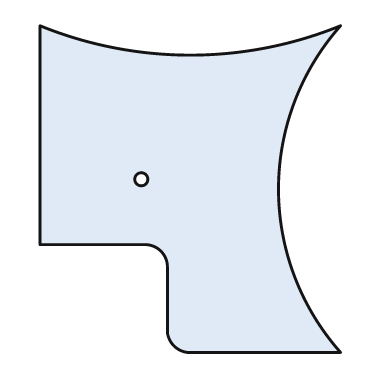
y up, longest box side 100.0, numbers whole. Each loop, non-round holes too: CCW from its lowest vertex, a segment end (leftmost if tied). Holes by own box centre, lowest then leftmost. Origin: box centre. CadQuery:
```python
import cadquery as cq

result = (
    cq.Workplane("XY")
    .moveTo(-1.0, -50.0)
    .lineTo(46.0, -50.0)
    .threePointArc((27.0, 0.0), (46.0, 50.0))
    .threePointArc((0.0, 41.0), (-46.0, 50.0))
    .lineTo(-46.0, -17.0)
    .lineTo(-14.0, -17.0)
    .threePointArc((-9.0, -19.0), (-7.0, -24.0))
    .lineTo(-7.0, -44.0)
    .threePointArc((-5.0, -48.0), (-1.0, -50.0))
    .close()
    .moveTo(-15.0, 3.0)
    .circle(2.0)
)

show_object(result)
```